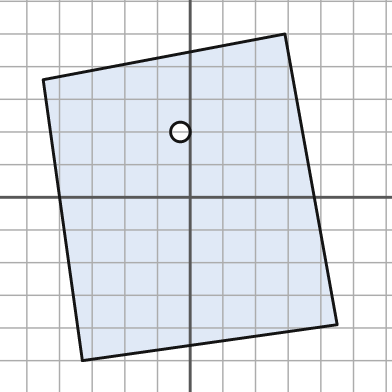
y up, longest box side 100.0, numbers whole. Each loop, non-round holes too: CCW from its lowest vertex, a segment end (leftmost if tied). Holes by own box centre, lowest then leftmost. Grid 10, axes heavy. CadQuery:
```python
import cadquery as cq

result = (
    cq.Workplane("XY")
    .moveTo(-33.0, -50.0)
    .lineTo(45.0, -39.0)
    .lineTo(29.0, 50.0)
    .lineTo(-45.0, 36.0)
    .close()
    .moveTo(-3.0, 20.0)
    .circle(3.0)
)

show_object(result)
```